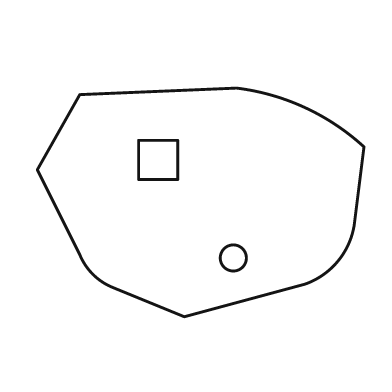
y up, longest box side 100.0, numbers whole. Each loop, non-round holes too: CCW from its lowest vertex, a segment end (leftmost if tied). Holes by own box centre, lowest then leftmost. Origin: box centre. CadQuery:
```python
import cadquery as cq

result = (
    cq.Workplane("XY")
    .moveTo(-5.0, -35.0)
    .lineTo(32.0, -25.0)
    .threePointArc((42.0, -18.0), (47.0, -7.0))
    .lineTo(50.0, 17.0)
    .threePointArc((32.0, 29.0), (11.0, 35.0))
    .lineTo(-37.0, 33.0)
    .lineTo(-50.0, 10.0)
    .lineTo(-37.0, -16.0)
    .threePointArc((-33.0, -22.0), (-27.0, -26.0))
    .close()
    .moveTo(10.0, -17.0)
    .circle(4.0)
    .moveTo(-19.0, 7.0)
    .lineTo(-7.0, 7.0)
    .lineTo(-7.0, 19.0)
    .lineTo(-19.0, 19.0)
    .close()
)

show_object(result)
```